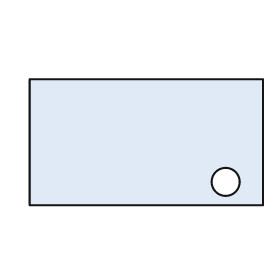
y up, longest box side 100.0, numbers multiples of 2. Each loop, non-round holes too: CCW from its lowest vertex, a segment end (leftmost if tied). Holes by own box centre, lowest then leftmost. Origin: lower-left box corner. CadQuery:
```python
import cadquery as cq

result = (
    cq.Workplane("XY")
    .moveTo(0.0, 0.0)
    .lineTo(100.0, 0.0)
    .lineTo(100.0, 54.0)
    .lineTo(0.0, 54.0)
    .close()
    .moveTo(84.0, 10.0)
    .circle(6.0)
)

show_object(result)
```